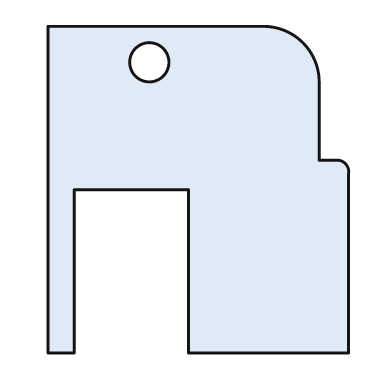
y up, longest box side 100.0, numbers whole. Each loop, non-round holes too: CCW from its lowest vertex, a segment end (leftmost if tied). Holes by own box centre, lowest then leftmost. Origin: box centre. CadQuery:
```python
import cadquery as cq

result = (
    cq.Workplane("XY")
    .moveTo(-46.0, -50.0)
    .lineTo(-38.0, -50.0)
    .lineTo(-38.0, 0.0)
    .lineTo(-3.0, 0.0)
    .lineTo(-3.0, -50.0)
    .lineTo(46.0, -50.0)
    .lineTo(46.0, 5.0)
    .threePointArc((45.0, 8.0), (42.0, 9.0))
    .lineTo(37.0, 9.0)
    .lineTo(37.0, 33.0)
    .threePointArc((32.0, 45.0), (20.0, 50.0))
    .lineTo(-46.0, 50.0)
    .close()
    .moveTo(-15.0, 39.0)
    .circle(6.0)
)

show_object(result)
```